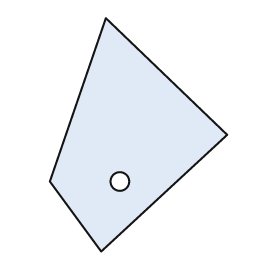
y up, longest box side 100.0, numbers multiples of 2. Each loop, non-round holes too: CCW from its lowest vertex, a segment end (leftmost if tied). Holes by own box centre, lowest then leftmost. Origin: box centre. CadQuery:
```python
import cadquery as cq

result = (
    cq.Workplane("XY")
    .moveTo(-16.0, -50.0)
    .lineTo(38.0, 0.0)
    .lineTo(-14.0, 50.0)
    .lineTo(-38.0, -20.0)
    .close()
    .moveTo(-8.0, -20.0)
    .circle(4.0)
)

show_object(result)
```